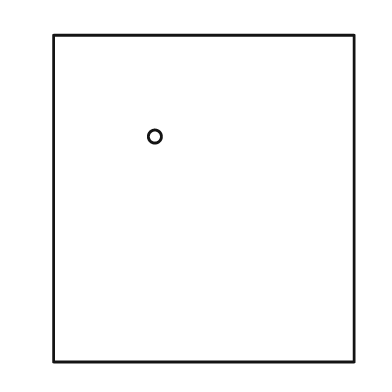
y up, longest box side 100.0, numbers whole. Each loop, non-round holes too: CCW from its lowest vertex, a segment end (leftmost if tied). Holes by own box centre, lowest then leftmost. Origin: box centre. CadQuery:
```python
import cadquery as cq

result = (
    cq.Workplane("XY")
    .moveTo(-46.0, -50.0)
    .lineTo(46.0, -50.0)
    .lineTo(46.0, 50.0)
    .lineTo(-46.0, 50.0)
    .close()
    .moveTo(-15.0, 19.0)
    .circle(2.0)
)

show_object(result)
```